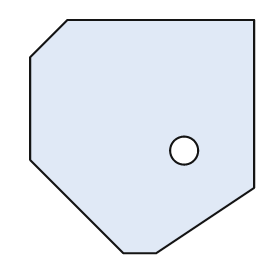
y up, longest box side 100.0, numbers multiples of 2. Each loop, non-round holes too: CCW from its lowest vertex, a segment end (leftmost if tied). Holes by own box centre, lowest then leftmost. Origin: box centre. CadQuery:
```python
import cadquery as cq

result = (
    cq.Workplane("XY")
    .moveTo(-8.0, -50.0)
    .lineTo(6.0, -50.0)
    .lineTo(48.0, -22.0)
    .lineTo(48.0, 50.0)
    .lineTo(-32.0, 50.0)
    .lineTo(-48.0, 34.0)
    .lineTo(-48.0, -10.0)
    .close()
    .moveTo(18.0, -6.0)
    .circle(6.0)
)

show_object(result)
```